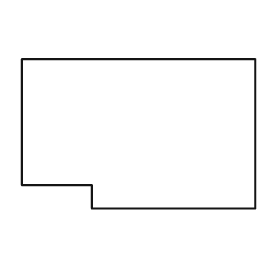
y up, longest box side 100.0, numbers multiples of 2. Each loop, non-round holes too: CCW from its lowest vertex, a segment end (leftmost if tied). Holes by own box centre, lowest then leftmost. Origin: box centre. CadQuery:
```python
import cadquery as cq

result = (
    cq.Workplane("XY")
    .moveTo(-20.0, -32.0)
    .lineTo(50.0, -32.0)
    .lineTo(50.0, 32.0)
    .lineTo(-50.0, 32.0)
    .lineTo(-50.0, -22.0)
    .lineTo(-20.0, -22.0)
    .close()
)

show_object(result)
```